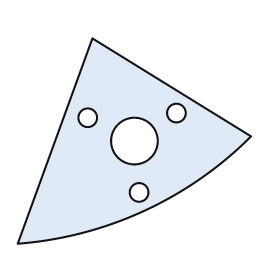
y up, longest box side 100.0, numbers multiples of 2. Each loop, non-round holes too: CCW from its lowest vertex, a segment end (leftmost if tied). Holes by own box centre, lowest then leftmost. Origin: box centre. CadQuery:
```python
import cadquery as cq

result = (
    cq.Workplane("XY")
    .moveTo(-50.0, -44.0)
    .threePointArc((4.0, -30.0), (50.0, 2.0))
    .lineTo(-18.0, 44.0)
    .close()
    .moveTo(2.0, -22.0)
    .circle(4.0)
    .moveTo(0.0, 0.0)
    .circle(10.0)
    .moveTo(-20.0, 10.0)
    .circle(4.0)
    .moveTo(18.0, 12.0)
    .circle(4.0)
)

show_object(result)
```